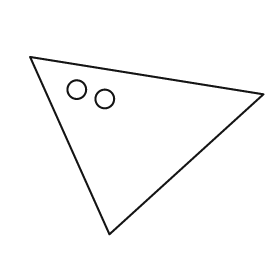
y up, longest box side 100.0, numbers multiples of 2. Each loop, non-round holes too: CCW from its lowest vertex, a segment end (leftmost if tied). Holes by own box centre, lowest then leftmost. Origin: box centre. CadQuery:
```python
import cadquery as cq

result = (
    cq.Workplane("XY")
    .moveTo(-16.0, -38.0)
    .lineTo(50.0, 22.0)
    .lineTo(-50.0, 38.0)
    .close()
    .moveTo(-18.0, 20.0)
    .circle(4.0)
    .moveTo(-30.0, 24.0)
    .circle(4.0)
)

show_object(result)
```